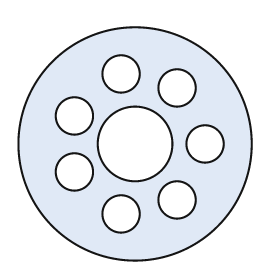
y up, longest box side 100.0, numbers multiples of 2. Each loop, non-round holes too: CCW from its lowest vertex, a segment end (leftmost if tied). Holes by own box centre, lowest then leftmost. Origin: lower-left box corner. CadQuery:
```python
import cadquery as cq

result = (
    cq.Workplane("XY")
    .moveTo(50.0, 50.0)
    .circle(50.0)
    .moveTo(44.0, 20.0)
    .circle(8.0)
    .moveTo(68.0, 26.0)
    .circle(8.0)
    .moveTo(24.0, 38.0)
    .circle(8.0)
    .moveTo(50.0, 50.0)
    .circle(16.0)
    .moveTo(80.0, 50.0)
    .circle(8.0)
    .moveTo(24.0, 62.0)
    .circle(8.0)
    .moveTo(68.0, 74.0)
    .circle(8.0)
    .moveTo(44.0, 80.0)
    .circle(8.0)
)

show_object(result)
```